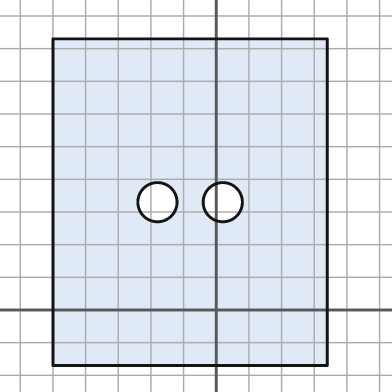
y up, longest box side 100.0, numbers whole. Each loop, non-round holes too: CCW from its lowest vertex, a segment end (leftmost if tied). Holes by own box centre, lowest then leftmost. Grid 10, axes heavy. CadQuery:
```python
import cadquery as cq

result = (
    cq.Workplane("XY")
    .moveTo(-50.0, -17.0)
    .lineTo(34.0, -17.0)
    .lineTo(34.0, 83.0)
    .lineTo(-50.0, 83.0)
    .close()
    .moveTo(-18.0, 33.0)
    .circle(6.0)
    .moveTo(2.0, 33.0)
    .circle(6.0)
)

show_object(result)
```